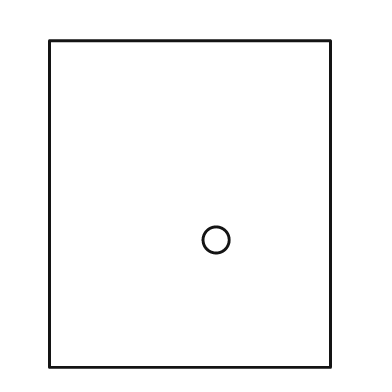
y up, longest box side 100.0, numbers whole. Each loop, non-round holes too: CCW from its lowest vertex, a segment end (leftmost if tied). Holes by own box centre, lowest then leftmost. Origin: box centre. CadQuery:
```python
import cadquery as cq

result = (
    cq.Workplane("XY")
    .moveTo(-43.0, -50.0)
    .lineTo(43.0, -50.0)
    .lineTo(43.0, 50.0)
    .lineTo(-43.0, 50.0)
    .close()
    .moveTo(8.0, -11.0)
    .circle(4.0)
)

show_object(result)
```